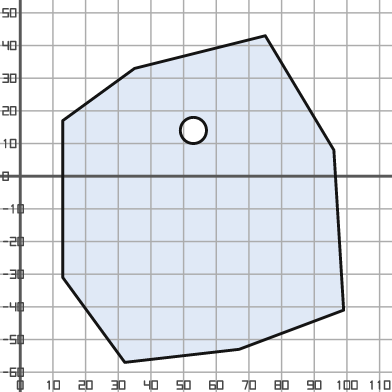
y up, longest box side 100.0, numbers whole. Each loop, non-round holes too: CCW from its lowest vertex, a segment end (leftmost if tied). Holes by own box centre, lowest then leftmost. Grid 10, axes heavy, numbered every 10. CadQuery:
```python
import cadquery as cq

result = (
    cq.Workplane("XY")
    .moveTo(32.0, -57.0)
    .lineTo(67.0, -53.0)
    .lineTo(99.0, -41.0)
    .lineTo(96.0, 8.0)
    .lineTo(75.0, 43.0)
    .lineTo(35.0, 33.0)
    .lineTo(13.0, 17.0)
    .lineTo(13.0, -31.0)
    .close()
    .moveTo(53.0, 14.0)
    .circle(4.0)
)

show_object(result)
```